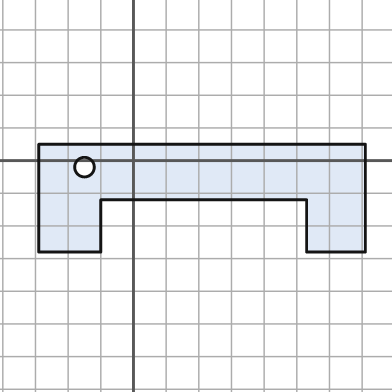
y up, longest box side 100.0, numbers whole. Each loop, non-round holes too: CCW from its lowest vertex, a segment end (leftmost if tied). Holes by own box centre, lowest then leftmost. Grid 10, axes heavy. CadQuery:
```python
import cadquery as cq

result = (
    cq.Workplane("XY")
    .moveTo(-29.0, -28.0)
    .lineTo(-10.0, -28.0)
    .lineTo(-10.0, -12.0)
    .lineTo(53.0, -12.0)
    .lineTo(53.0, -28.0)
    .lineTo(71.0, -28.0)
    .lineTo(71.0, 5.0)
    .lineTo(-29.0, 5.0)
    .close()
    .moveTo(-15.0, -2.0)
    .circle(3.0)
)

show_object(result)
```